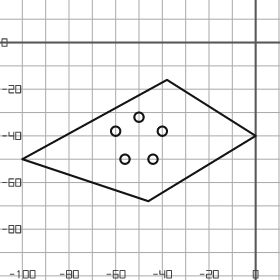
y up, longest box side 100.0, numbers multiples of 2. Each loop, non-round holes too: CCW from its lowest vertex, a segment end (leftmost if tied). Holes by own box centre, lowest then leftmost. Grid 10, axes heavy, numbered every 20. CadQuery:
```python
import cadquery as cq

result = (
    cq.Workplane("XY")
    .moveTo(-46.0, -68.0)
    .lineTo(0.0, -40.0)
    .lineTo(-38.0, -16.0)
    .lineTo(-100.0, -50.0)
    .close()
    .moveTo(-56.0, -50.0)
    .circle(2.0)
    .moveTo(-44.0, -50.0)
    .circle(2.0)
    .moveTo(-60.0, -38.0)
    .circle(2.0)
    .moveTo(-40.0, -38.0)
    .circle(2.0)
    .moveTo(-50.0, -32.0)
    .circle(2.0)
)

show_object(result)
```